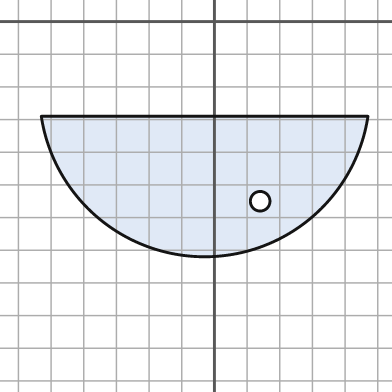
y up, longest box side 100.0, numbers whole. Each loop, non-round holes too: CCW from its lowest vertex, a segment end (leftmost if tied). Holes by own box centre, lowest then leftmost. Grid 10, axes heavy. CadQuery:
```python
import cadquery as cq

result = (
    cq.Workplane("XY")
    .moveTo(-53.0, -29.0)
    .threePointArc((-3.0, -72.0), (47.0, -29.0))
    .close()
    .moveTo(14.0, -55.0)
    .circle(3.0)
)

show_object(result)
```